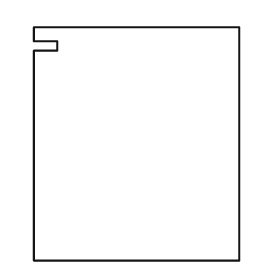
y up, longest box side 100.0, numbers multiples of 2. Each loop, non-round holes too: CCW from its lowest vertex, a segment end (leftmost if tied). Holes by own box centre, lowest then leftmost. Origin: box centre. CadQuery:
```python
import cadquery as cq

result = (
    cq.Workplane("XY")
    .moveTo(-44.0, -50.0)
    .lineTo(44.0, -50.0)
    .lineTo(44.0, 50.0)
    .lineTo(-44.0, 50.0)
    .lineTo(-44.0, 44.0)
    .lineTo(-34.0, 44.0)
    .lineTo(-34.0, 40.0)
    .lineTo(-44.0, 40.0)
    .close()
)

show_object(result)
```